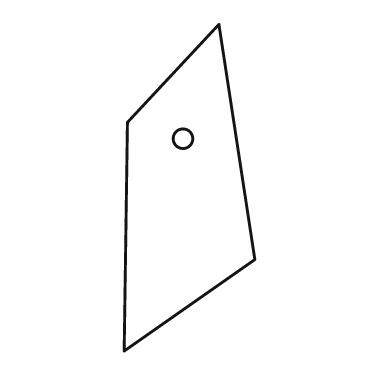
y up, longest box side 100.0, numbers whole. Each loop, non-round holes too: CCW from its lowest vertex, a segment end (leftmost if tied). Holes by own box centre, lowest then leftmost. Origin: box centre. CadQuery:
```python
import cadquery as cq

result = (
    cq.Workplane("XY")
    .moveTo(-20.0, -50.0)
    .lineTo(20.0, -22.0)
    .lineTo(9.0, 50.0)
    .lineTo(-19.0, 20.0)
    .close()
    .moveTo(-2.0, 15.0)
    .circle(3.0)
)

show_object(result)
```